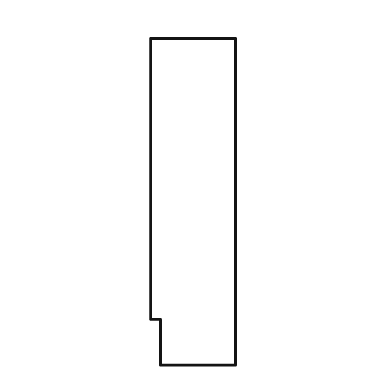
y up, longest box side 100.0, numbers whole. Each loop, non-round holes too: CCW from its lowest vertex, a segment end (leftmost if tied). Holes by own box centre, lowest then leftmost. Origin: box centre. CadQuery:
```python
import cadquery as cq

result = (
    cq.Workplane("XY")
    .moveTo(-10.0, -50.0)
    .lineTo(13.0, -50.0)
    .lineTo(13.0, 50.0)
    .lineTo(-13.0, 50.0)
    .lineTo(-13.0, -36.0)
    .lineTo(-10.0, -36.0)
    .close()
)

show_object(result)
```